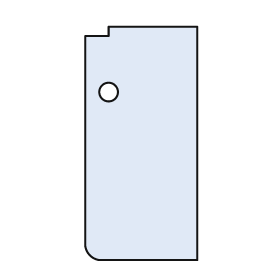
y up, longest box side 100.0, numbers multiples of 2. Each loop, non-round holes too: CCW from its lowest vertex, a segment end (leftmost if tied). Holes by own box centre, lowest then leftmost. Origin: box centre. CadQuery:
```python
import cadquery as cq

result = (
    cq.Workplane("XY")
    .moveTo(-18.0, -50.0)
    .lineTo(24.0, -50.0)
    .lineTo(24.0, 50.0)
    .lineTo(-14.0, 50.0)
    .lineTo(-14.0, 46.0)
    .lineTo(-24.0, 46.0)
    .lineTo(-24.0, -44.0)
    .threePointArc((-22.0, -48.0), (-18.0, -50.0))
    .close()
    .moveTo(-14.0, 22.0)
    .circle(4.0)
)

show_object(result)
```